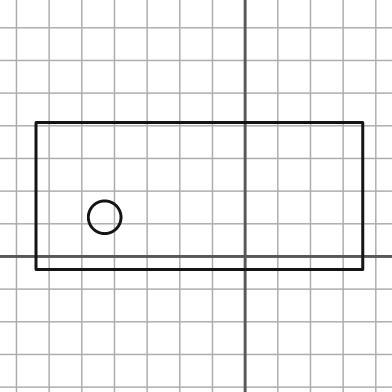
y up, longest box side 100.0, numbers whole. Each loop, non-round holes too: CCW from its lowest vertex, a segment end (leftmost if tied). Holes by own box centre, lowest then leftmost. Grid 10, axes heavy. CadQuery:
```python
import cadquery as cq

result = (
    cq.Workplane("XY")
    .moveTo(-64.0, -4.0)
    .lineTo(36.0, -4.0)
    .lineTo(36.0, 41.0)
    .lineTo(-64.0, 41.0)
    .close()
    .moveTo(-43.0, 12.0)
    .circle(5.0)
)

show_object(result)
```